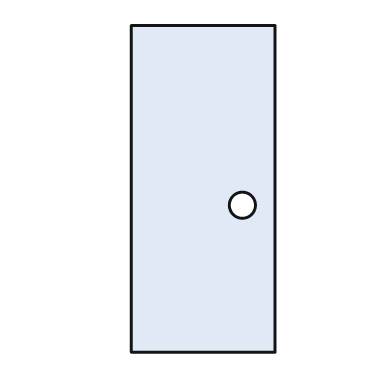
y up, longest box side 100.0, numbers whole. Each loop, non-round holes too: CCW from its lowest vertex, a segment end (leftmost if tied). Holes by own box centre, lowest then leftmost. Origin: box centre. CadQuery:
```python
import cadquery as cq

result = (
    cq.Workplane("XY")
    .moveTo(-22.0, -50.0)
    .lineTo(22.0, -50.0)
    .lineTo(22.0, 50.0)
    .lineTo(-22.0, 50.0)
    .close()
    .moveTo(12.0, -5.0)
    .circle(4.0)
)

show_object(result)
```